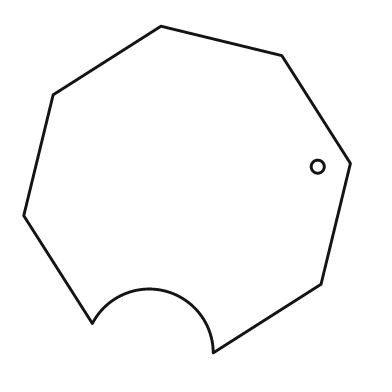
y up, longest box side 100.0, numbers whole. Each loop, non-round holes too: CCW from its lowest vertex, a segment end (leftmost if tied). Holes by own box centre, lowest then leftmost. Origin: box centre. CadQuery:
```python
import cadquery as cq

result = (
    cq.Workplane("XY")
    .moveTo(8.0, -50.0)
    .lineTo(41.0, -29.0)
    .lineTo(50.0, 8.0)
    .lineTo(29.0, 41.0)
    .lineTo(-8.0, 50.0)
    .lineTo(-41.0, 29.0)
    .lineTo(-50.0, -8.0)
    .lineTo(-29.0, -41.0)
    .threePointArc((-7.0, -31.0), (8.0, -50.0))
    .close()
    .moveTo(40.0, 7.0)
    .circle(2.0)
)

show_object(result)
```